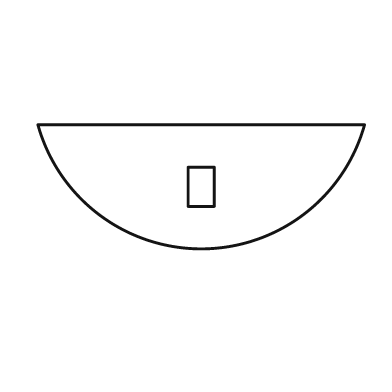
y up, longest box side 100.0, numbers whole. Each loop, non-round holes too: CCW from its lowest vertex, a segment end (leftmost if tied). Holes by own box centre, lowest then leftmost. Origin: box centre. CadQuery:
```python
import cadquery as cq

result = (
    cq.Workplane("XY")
    .moveTo(-50.0, 19.0)
    .threePointArc((0.0, -19.0), (50.0, 19.0))
    .close()
    .moveTo(-4.0, -6.0)
    .lineTo(4.0, -6.0)
    .lineTo(4.0, 6.0)
    .lineTo(-4.0, 6.0)
    .close()
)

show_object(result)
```